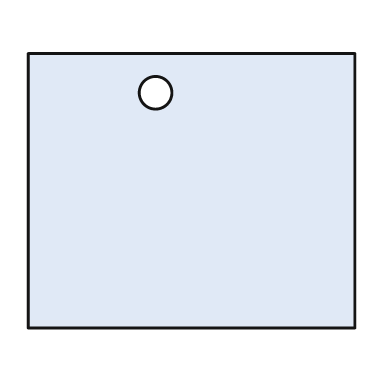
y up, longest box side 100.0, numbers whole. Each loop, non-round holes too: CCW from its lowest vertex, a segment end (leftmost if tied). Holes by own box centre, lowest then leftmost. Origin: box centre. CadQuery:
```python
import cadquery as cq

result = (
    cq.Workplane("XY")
    .moveTo(-50.0, -42.0)
    .lineTo(50.0, -42.0)
    .lineTo(50.0, 42.0)
    .lineTo(-50.0, 42.0)
    .close()
    .moveTo(-11.0, 30.0)
    .circle(5.0)
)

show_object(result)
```